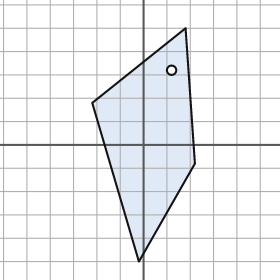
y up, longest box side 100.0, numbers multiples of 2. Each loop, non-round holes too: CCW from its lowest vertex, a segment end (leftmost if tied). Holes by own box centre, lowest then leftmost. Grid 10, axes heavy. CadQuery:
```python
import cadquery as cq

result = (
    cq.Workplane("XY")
    .moveTo(-2.0, -50.0)
    .lineTo(22.0, -8.0)
    .lineTo(18.0, 50.0)
    .lineTo(-22.0, 18.0)
    .close()
    .moveTo(12.0, 32.0)
    .circle(2.0)
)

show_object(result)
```